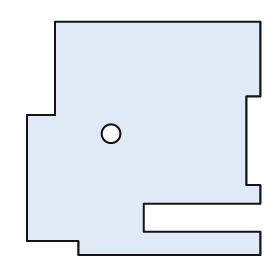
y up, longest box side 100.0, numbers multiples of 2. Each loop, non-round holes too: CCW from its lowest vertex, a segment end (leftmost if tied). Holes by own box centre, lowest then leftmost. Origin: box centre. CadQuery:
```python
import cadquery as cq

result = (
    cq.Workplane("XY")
    .moveTo(-28.0, -50.0)
    .lineTo(50.0, -50.0)
    .lineTo(50.0, -40.0)
    .lineTo(0.0, -40.0)
    .lineTo(0.0, -28.0)
    .lineTo(50.0, -28.0)
    .lineTo(50.0, -20.0)
    .lineTo(44.0, -20.0)
    .lineTo(44.0, 18.0)
    .lineTo(50.0, 18.0)
    .lineTo(50.0, 50.0)
    .lineTo(-38.0, 50.0)
    .lineTo(-38.0, 10.0)
    .lineTo(-50.0, 10.0)
    .lineTo(-50.0, -44.0)
    .lineTo(-28.0, -44.0)
    .close()
    .moveTo(-14.0, 2.0)
    .circle(4.0)
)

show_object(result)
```